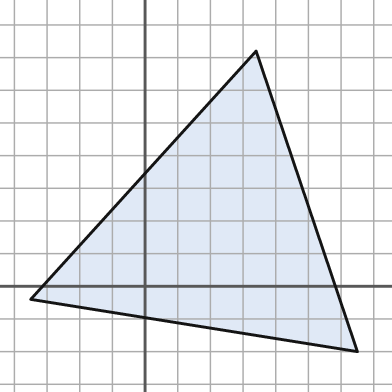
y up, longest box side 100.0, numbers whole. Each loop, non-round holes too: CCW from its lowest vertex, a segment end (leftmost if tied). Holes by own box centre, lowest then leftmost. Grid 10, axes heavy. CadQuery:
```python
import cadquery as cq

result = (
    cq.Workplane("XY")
    .moveTo(65.0, -20.0)
    .lineTo(34.0, 72.0)
    .lineTo(-35.0, -4.0)
    .close()
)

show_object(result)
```